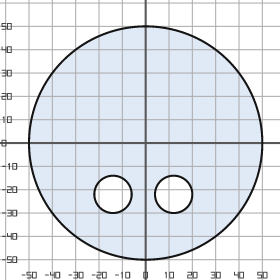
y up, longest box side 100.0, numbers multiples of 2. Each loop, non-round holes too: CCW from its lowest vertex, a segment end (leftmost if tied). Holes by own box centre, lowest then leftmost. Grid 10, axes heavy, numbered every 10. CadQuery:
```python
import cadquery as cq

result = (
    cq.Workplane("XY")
    .moveTo(0.0, 0.0)
    .circle(50.0)
    .moveTo(-14.0, -22.0)
    .circle(8.0)
    .moveTo(12.0, -22.0)
    .circle(8.0)
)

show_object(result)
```